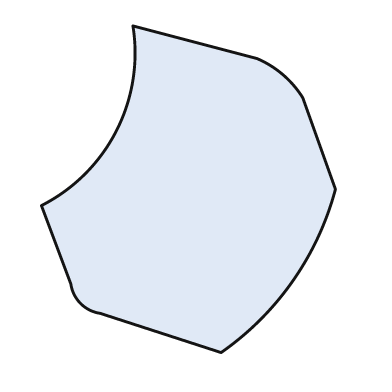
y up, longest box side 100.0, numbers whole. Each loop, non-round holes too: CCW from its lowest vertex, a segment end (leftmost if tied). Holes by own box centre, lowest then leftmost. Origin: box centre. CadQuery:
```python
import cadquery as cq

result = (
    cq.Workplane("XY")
    .moveTo(10.0, -50.0)
    .threePointArc((32.0, -28.0), (45.0, 0.0))
    .lineTo(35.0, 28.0)
    .threePointArc((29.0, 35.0), (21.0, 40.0))
    .lineTo(-17.0, 50.0)
    .threePointArc((-22.0, 18.0), (-45.0, -5.0))
    .lineTo(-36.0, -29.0)
    .threePointArc((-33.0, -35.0), (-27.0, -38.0))
    .close()
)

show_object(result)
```